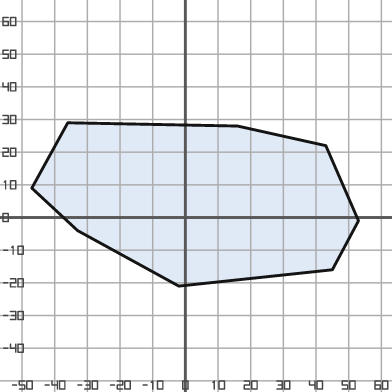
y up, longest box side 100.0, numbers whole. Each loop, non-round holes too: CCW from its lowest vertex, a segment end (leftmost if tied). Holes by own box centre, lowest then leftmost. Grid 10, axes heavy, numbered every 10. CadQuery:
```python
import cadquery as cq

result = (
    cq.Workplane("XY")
    .moveTo(-2.0, -21.0)
    .lineTo(45.0, -16.0)
    .lineTo(53.0, -1.0)
    .lineTo(43.0, 22.0)
    .lineTo(16.0, 28.0)
    .lineTo(-36.0, 29.0)
    .lineTo(-47.0, 9.0)
    .lineTo(-33.0, -4.0)
    .close()
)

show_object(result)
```